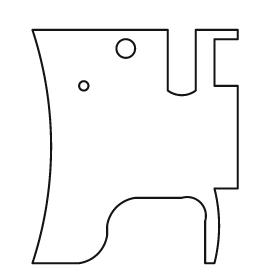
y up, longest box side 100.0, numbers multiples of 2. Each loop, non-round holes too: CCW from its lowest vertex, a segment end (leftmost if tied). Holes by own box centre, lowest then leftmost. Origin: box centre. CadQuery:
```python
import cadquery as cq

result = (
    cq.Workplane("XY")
    .moveTo(-44.0, -50.0)
    .lineTo(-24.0, -50.0)
    .threePointArc((-16.0, -46.0), (-12.0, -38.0))
    .lineTo(-12.0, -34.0)
    .threePointArc((-8.0, -26.0), (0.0, -22.0))
    .lineTo(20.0, -22.0)
    .threePointArc((28.0, -24.0), (30.0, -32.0))
    .lineTo(30.0, -50.0)
    .lineTo(34.0, -50.0)
    .threePointArc((36.0, -34.0), (34.0, -18.0))
    .lineTo(44.0, -18.0)
    .lineTo(44.0, 26.0)
    .lineTo(34.0, 26.0)
    .lineTo(34.0, 46.0)
    .lineTo(44.0, 46.0)
    .lineTo(44.0, 50.0)
    .lineTo(26.0, 50.0)
    .lineTo(26.0, 24.0)
    .threePointArc((20.0, 22.0), (14.0, 24.0))
    .lineTo(14.0, 50.0)
    .lineTo(-44.0, 50.0)
    .threePointArc((-36.0, 0.0), (-44.0, -50.0))
    .close()
    .moveTo(-22.0, 26.0)
    .circle(2.0)
    .moveTo(-4.0, 42.0)
    .circle(4.0)
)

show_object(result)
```